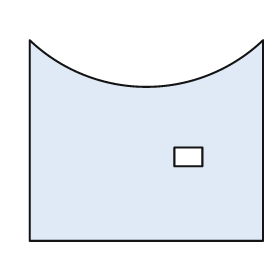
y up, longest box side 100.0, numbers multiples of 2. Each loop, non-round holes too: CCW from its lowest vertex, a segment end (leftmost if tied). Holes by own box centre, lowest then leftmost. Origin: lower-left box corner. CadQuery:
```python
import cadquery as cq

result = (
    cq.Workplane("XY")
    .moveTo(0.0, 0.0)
    .lineTo(100.0, 0.0)
    .lineTo(100.0, 86.0)
    .threePointArc((50.0, 66.0), (0.0, 86.0))
    .close()
    .moveTo(62.0, 32.0)
    .lineTo(74.0, 32.0)
    .lineTo(74.0, 40.0)
    .lineTo(62.0, 40.0)
    .close()
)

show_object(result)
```